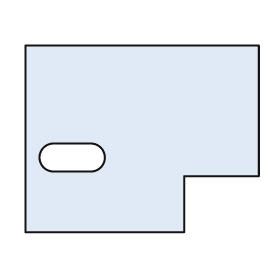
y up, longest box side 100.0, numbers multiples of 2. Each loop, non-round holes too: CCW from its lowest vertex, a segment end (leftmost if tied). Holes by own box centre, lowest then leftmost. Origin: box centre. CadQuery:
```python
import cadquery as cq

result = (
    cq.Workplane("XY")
    .moveTo(-50.0, -40.0)
    .lineTo(18.0, -40.0)
    .lineTo(18.0, -16.0)
    .lineTo(50.0, -16.0)
    .lineTo(50.0, 40.0)
    .lineTo(-50.0, 40.0)
    .close()
    .moveTo(-38.0, -14.0)
    .lineTo(-22.0, -14.0)
    .threePointArc((-16.0, -8.0), (-22.0, -2.0))
    .lineTo(-38.0, -2.0)
    .threePointArc((-44.0, -8.0), (-38.0, -14.0))
    .close()
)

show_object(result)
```